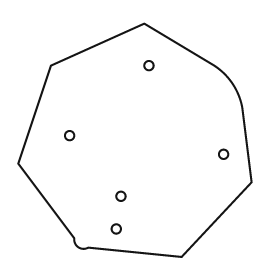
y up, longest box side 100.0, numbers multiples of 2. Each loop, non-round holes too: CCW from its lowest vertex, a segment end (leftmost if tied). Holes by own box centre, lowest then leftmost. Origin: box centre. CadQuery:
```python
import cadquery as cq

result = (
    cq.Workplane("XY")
    .moveTo(20.0, -50.0)
    .lineTo(50.0, -18.0)
    .lineTo(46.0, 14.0)
    .threePointArc((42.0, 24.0), (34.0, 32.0))
    .lineTo(4.0, 50.0)
    .lineTo(-36.0, 32.0)
    .lineTo(-50.0, -10.0)
    .lineTo(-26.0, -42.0)
    .threePointArc((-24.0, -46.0), (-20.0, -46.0))
    .close()
    .moveTo(-8.0, -38.0)
    .circle(2.0)
    .moveTo(-6.0, -24.0)
    .circle(2.0)
    .moveTo(38.0, -6.0)
    .circle(2.0)
    .moveTo(-28.0, 2.0)
    .circle(2.0)
    .moveTo(6.0, 32.0)
    .circle(2.0)
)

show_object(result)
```